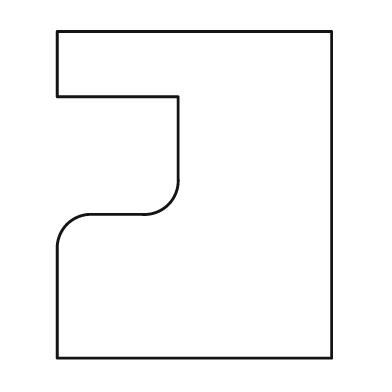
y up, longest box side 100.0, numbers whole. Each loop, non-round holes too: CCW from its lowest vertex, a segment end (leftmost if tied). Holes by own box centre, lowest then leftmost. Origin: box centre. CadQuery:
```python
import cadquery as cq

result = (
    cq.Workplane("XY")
    .moveTo(-42.0, -50.0)
    .lineTo(42.0, -50.0)
    .lineTo(42.0, 50.0)
    .lineTo(-42.0, 50.0)
    .lineTo(-42.0, 30.0)
    .lineTo(-5.0, 30.0)
    .lineTo(-5.0, 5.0)
    .threePointArc((-8.0, -3.0), (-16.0, -6.0))
    .lineTo(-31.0, -6.0)
    .threePointArc((-39.0, -9.0), (-42.0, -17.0))
    .close()
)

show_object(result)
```